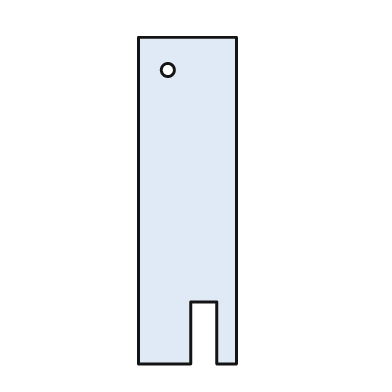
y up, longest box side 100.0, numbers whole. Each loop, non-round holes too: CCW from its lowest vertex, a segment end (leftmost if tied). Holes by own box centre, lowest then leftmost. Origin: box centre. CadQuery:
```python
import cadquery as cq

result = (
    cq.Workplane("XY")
    .moveTo(-15.0, -50.0)
    .lineTo(1.0, -50.0)
    .lineTo(1.0, -31.0)
    .lineTo(9.0, -31.0)
    .lineTo(9.0, -50.0)
    .lineTo(15.0, -50.0)
    .lineTo(15.0, 50.0)
    .lineTo(-15.0, 50.0)
    .close()
    .moveTo(-6.0, 40.0)
    .circle(2.0)
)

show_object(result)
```